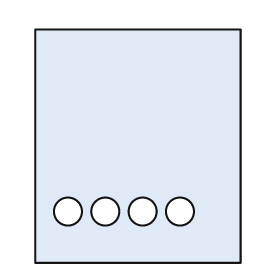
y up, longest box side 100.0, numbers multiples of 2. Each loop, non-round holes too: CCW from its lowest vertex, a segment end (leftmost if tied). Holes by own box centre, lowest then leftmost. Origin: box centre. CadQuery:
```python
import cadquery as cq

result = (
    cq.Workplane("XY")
    .moveTo(-44.0, -50.0)
    .lineTo(44.0, -50.0)
    .lineTo(44.0, 50.0)
    .lineTo(-44.0, 50.0)
    .close()
    .moveTo(-30.0, -28.0)
    .circle(6.0)
    .moveTo(-14.0, -28.0)
    .circle(6.0)
    .moveTo(2.0, -28.0)
    .circle(6.0)
    .moveTo(18.0, -28.0)
    .circle(6.0)
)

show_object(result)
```